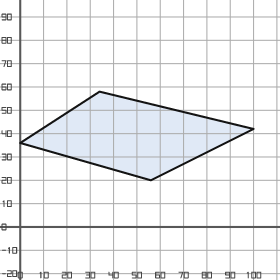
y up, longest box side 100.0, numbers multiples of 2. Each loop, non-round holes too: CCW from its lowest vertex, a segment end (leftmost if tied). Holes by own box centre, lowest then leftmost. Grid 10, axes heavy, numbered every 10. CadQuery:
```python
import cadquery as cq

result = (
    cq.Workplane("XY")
    .moveTo(56.0, 20.0)
    .lineTo(100.0, 42.0)
    .lineTo(34.0, 58.0)
    .lineTo(0.0, 36.0)
    .close()
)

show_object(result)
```